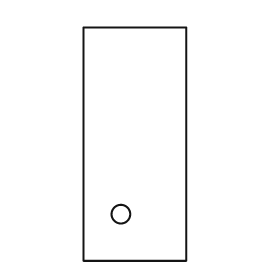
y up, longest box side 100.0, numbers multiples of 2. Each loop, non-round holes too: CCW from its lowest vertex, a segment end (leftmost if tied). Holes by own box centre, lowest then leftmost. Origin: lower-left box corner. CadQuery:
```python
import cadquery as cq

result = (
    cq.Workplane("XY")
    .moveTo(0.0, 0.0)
    .lineTo(44.0, 0.0)
    .lineTo(44.0, 100.0)
    .lineTo(0.0, 100.0)
    .close()
    .moveTo(16.0, 20.0)
    .circle(4.0)
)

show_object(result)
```